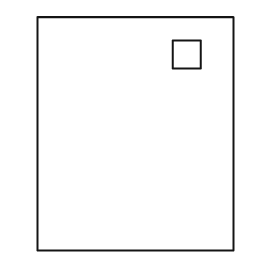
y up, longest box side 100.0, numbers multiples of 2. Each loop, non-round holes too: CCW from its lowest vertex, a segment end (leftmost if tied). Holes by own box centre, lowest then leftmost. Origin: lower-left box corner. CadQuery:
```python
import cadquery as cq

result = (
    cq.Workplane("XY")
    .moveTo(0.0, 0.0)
    .lineTo(84.0, 0.0)
    .lineTo(84.0, 100.0)
    .lineTo(0.0, 100.0)
    .close()
    .moveTo(58.0, 78.0)
    .lineTo(70.0, 78.0)
    .lineTo(70.0, 90.0)
    .lineTo(58.0, 90.0)
    .close()
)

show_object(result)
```